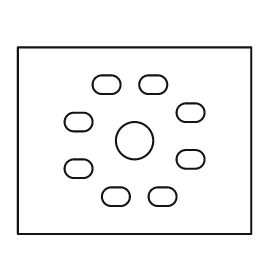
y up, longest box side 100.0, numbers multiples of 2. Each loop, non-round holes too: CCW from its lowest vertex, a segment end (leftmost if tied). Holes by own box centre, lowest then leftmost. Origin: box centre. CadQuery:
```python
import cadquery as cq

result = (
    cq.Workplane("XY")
    .moveTo(-50.0, -40.0)
    .lineTo(50.0, -40.0)
    .lineTo(50.0, 40.0)
    .lineTo(-50.0, 40.0)
    .close()
    .moveTo(-10.0, -28.0)
    .lineTo(-6.0, -28.0)
    .threePointArc((-2.0, -24.0), (-6.0, -20.0))
    .lineTo(-10.0, -20.0)
    .threePointArc((-14.0, -24.0), (-10.0, -28.0))
    .close()
    .moveTo(10.0, -28.0)
    .lineTo(14.0, -28.0)
    .threePointArc((18.0, -24.0), (14.0, -20.0))
    .lineTo(10.0, -20.0)
    .threePointArc((6.0, -24.0), (10.0, -28.0))
    .close()
    .moveTo(-26.0, -16.0)
    .lineTo(-22.0, -16.0)
    .threePointArc((-18.0, -12.0), (-22.0, -8.0))
    .lineTo(-26.0, -8.0)
    .threePointArc((-30.0, -12.0), (-26.0, -16.0))
    .close()
    .moveTo(22.0, -12.0)
    .lineTo(26.0, -12.0)
    .threePointArc((30.0, -8.0), (26.0, -4.0))
    .lineTo(22.0, -4.0)
    .threePointArc((18.0, -8.0), (22.0, -12.0))
    .close()
    .moveTo(0.0, 0.0)
    .circle(8.0)
    .moveTo(-26.0, 4.0)
    .lineTo(-22.0, 4.0)
    .threePointArc((-18.0, 8.0), (-22.0, 12.0))
    .lineTo(-26.0, 12.0)
    .threePointArc((-30.0, 8.0), (-26.0, 4.0))
    .close()
    .moveTo(22.0, 8.0)
    .lineTo(26.0, 8.0)
    .threePointArc((30.0, 12.0), (26.0, 16.0))
    .lineTo(22.0, 16.0)
    .threePointArc((18.0, 12.0), (22.0, 8.0))
    .close()
    .moveTo(-14.0, 20.0)
    .lineTo(-10.0, 20.0)
    .threePointArc((-6.0, 24.0), (-10.0, 28.0))
    .lineTo(-14.0, 28.0)
    .threePointArc((-18.0, 24.0), (-14.0, 20.0))
    .close()
    .moveTo(6.0, 20.0)
    .lineTo(10.0, 20.0)
    .threePointArc((14.0, 24.0), (10.0, 28.0))
    .lineTo(6.0, 28.0)
    .threePointArc((2.0, 24.0), (6.0, 20.0))
    .close()
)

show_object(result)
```